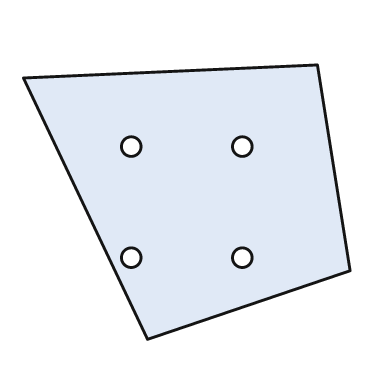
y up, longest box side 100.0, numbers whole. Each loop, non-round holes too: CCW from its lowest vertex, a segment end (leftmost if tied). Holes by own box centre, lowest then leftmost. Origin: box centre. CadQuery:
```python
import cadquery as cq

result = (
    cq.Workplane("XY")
    .moveTo(-12.0, -42.0)
    .lineTo(50.0, -21.0)
    .lineTo(40.0, 42.0)
    .lineTo(-50.0, 38.0)
    .close()
    .moveTo(-17.0, -17.0)
    .circle(3.0)
    .moveTo(17.0, -17.0)
    .circle(3.0)
    .moveTo(-17.0, 17.0)
    .circle(3.0)
    .moveTo(17.0, 17.0)
    .circle(3.0)
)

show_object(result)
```